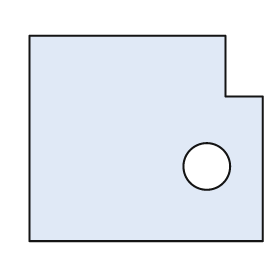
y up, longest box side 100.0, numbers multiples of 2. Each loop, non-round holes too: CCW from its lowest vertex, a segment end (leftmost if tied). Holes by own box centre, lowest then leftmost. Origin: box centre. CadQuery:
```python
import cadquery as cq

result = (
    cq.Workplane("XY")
    .moveTo(-50.0, -44.0)
    .lineTo(50.0, -44.0)
    .lineTo(50.0, 18.0)
    .lineTo(34.0, 18.0)
    .lineTo(34.0, 44.0)
    .lineTo(-50.0, 44.0)
    .close()
    .moveTo(26.0, -12.0)
    .circle(10.0)
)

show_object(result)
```